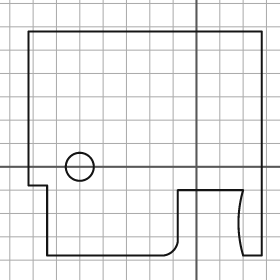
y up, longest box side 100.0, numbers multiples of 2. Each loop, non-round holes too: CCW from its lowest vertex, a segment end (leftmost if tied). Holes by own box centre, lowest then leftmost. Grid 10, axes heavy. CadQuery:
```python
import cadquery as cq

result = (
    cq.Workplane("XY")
    .moveTo(-64.0, -38.0)
    .lineTo(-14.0, -38.0)
    .threePointArc((-10.0, -36.0), (-8.0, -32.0))
    .lineTo(-8.0, -10.0)
    .lineTo(20.0, -10.0)
    .threePointArc((18.0, -24.0), (20.0, -38.0))
    .lineTo(28.0, -38.0)
    .lineTo(28.0, 58.0)
    .lineTo(-72.0, 58.0)
    .lineTo(-72.0, -8.0)
    .lineTo(-64.0, -8.0)
    .close()
    .moveTo(-50.0, 0.0)
    .circle(6.0)
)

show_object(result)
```